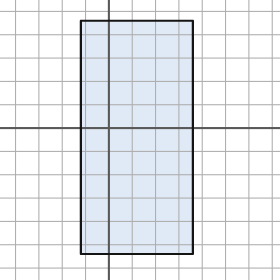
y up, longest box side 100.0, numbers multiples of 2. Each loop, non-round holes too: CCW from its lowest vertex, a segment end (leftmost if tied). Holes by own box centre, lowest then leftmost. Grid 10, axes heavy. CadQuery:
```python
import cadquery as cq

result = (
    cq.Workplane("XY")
    .moveTo(-12.0, -54.0)
    .lineTo(36.0, -54.0)
    .lineTo(36.0, 46.0)
    .lineTo(-12.0, 46.0)
    .close()
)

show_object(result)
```